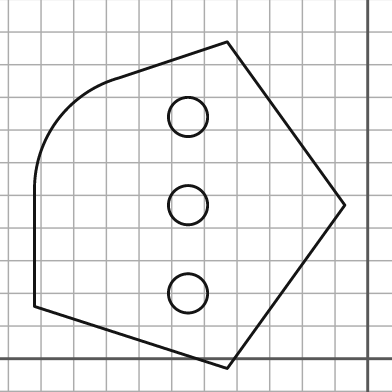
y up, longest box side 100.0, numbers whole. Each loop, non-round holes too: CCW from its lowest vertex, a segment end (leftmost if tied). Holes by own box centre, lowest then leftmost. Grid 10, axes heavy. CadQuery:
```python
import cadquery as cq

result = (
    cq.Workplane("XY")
    .moveTo(-43.0, -3.0)
    .lineTo(-7.0, 47.0)
    .lineTo(-43.0, 97.0)
    .lineTo(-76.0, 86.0)
    .threePointArc((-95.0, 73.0), (-102.0, 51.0))
    .lineTo(-102.0, 16.0)
    .close()
    .moveTo(-55.0, 20.0)
    .circle(6.0)
    .moveTo(-55.0, 47.0)
    .circle(6.0)
    .moveTo(-55.0, 74.0)
    .circle(6.0)
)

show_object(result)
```